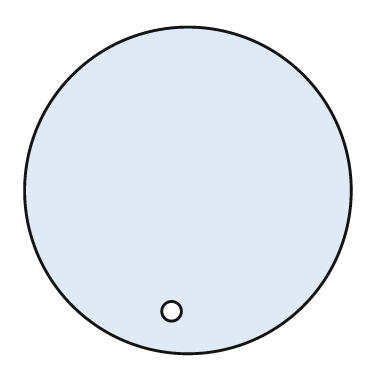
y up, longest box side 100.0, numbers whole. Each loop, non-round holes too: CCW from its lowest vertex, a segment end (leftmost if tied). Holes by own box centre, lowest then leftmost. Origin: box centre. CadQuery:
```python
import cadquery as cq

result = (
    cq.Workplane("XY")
    .moveTo(0.0, 0.0)
    .circle(50.0)
    .moveTo(-5.0, -37.0)
    .circle(3.0)
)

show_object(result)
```